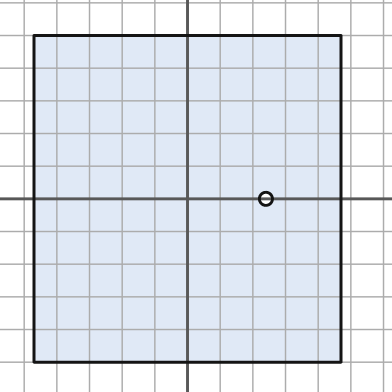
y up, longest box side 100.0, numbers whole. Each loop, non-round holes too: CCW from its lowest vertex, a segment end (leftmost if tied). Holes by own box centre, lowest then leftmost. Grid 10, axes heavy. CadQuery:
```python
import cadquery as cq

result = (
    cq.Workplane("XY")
    .moveTo(-47.0, -50.0)
    .lineTo(47.0, -50.0)
    .lineTo(47.0, 50.0)
    .lineTo(-47.0, 50.0)
    .close()
    .moveTo(24.0, 0.0)
    .circle(2.0)
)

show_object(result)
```